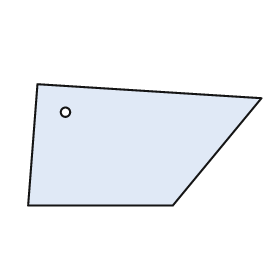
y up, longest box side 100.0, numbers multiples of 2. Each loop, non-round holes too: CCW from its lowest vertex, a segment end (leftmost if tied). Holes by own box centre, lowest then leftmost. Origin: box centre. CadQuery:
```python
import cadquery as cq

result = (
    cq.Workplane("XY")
    .moveTo(-50.0, -26.0)
    .lineTo(12.0, -26.0)
    .lineTo(50.0, 20.0)
    .lineTo(-46.0, 26.0)
    .close()
    .moveTo(-34.0, 14.0)
    .circle(2.0)
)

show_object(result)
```